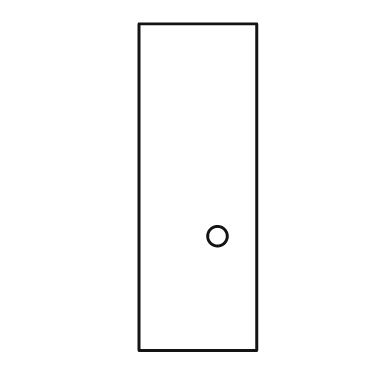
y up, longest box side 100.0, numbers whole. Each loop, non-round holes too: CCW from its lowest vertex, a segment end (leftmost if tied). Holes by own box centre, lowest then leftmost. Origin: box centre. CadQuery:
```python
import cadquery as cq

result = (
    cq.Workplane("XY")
    .moveTo(-18.0, -50.0)
    .lineTo(18.0, -50.0)
    .lineTo(18.0, 50.0)
    .lineTo(-18.0, 50.0)
    .close()
    .moveTo(6.0, -15.0)
    .circle(3.0)
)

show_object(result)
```